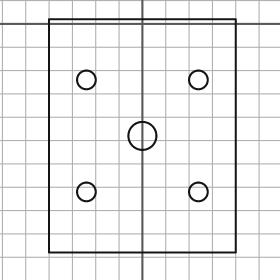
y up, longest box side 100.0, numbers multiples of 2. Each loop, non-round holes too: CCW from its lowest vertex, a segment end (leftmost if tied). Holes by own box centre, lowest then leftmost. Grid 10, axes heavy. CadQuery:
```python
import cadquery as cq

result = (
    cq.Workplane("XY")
    .moveTo(-40.0, -98.0)
    .lineTo(40.0, -98.0)
    .lineTo(40.0, 2.0)
    .lineTo(-40.0, 2.0)
    .close()
    .moveTo(-24.0, -72.0)
    .circle(4.0)
    .moveTo(24.0, -72.0)
    .circle(4.0)
    .moveTo(0.0, -48.0)
    .circle(6.0)
    .moveTo(-24.0, -24.0)
    .circle(4.0)
    .moveTo(24.0, -24.0)
    .circle(4.0)
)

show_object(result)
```